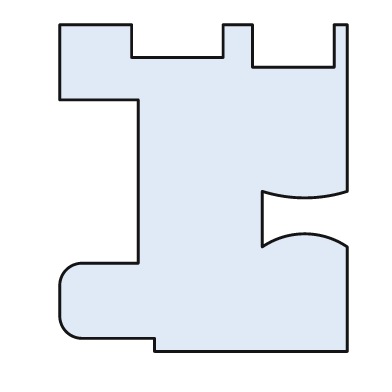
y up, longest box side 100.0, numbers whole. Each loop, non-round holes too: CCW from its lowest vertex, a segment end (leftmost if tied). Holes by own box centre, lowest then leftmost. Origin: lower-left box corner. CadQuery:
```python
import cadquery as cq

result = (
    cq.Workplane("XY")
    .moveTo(29.0, 0.0)
    .lineTo(88.0, 0.0)
    .lineTo(88.0, 32.0)
    .threePointArc((75.0, 36.0), (62.0, 32.0))
    .lineTo(62.0, 49.0)
    .threePointArc((75.0, 47.0), (88.0, 49.0))
    .lineTo(88.0, 100.0)
    .lineTo(84.0, 100.0)
    .lineTo(84.0, 87.0)
    .lineTo(59.0, 87.0)
    .lineTo(59.0, 100.0)
    .lineTo(50.0, 100.0)
    .lineTo(50.0, 90.0)
    .lineTo(22.0, 90.0)
    .lineTo(22.0, 100.0)
    .lineTo(0.0, 100.0)
    .lineTo(0.0, 77.0)
    .lineTo(24.0, 77.0)
    .lineTo(24.0, 27.0)
    .lineTo(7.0, 27.0)
    .threePointArc((2.0, 25.0), (0.0, 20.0))
    .lineTo(0.0, 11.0)
    .threePointArc((2.0, 6.0), (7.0, 4.0))
    .lineTo(29.0, 4.0)
    .close()
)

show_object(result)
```